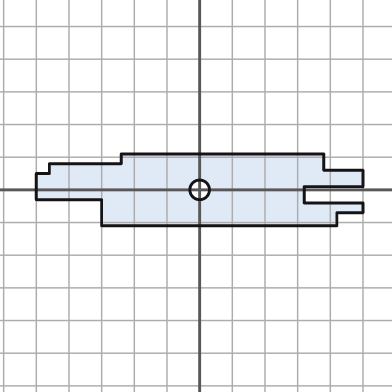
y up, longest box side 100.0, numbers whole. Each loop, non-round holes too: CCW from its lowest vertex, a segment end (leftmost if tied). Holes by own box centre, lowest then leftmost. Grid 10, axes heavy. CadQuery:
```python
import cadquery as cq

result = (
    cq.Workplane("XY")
    .moveTo(-30.0, -11.0)
    .lineTo(42.0, -11.0)
    .lineTo(42.0, -7.0)
    .lineTo(50.0, -7.0)
    .lineTo(50.0, -4.0)
    .lineTo(32.0, -4.0)
    .lineTo(32.0, 1.0)
    .lineTo(50.0, 1.0)
    .lineTo(50.0, 6.0)
    .lineTo(38.0, 6.0)
    .lineTo(38.0, 11.0)
    .lineTo(-24.0, 11.0)
    .lineTo(-24.0, 8.0)
    .lineTo(-46.0, 8.0)
    .lineTo(-46.0, 5.0)
    .lineTo(-50.0, 5.0)
    .lineTo(-50.0, -3.0)
    .lineTo(-30.0, -3.0)
    .close()
    .moveTo(0.0, 0.0)
    .circle(3.0)
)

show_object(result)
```